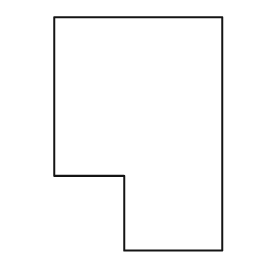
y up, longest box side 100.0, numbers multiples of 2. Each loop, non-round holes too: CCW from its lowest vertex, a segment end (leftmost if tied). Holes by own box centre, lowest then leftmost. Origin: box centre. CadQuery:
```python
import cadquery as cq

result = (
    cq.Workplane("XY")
    .moveTo(-6.0, -50.0)
    .lineTo(36.0, -50.0)
    .lineTo(36.0, 50.0)
    .lineTo(-36.0, 50.0)
    .lineTo(-36.0, -18.0)
    .lineTo(-6.0, -18.0)
    .close()
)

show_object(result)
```